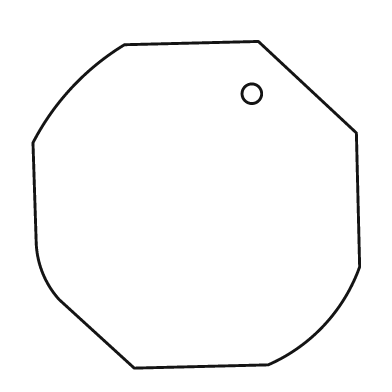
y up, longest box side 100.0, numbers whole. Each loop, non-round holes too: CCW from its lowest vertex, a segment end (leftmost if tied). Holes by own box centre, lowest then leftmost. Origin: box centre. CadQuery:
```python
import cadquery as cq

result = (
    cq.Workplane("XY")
    .moveTo(-19.0, -50.0)
    .lineTo(22.0, -49.0)
    .threePointArc((39.0, -37.0), (50.0, -19.0))
    .lineTo(49.0, 22.0)
    .lineTo(19.0, 50.0)
    .lineTo(-22.0, 49.0)
    .threePointArc((-38.0, 36.0), (-50.0, 19.0))
    .lineTo(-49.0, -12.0)
    .threePointArc((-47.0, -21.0), (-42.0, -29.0))
    .close()
    .moveTo(17.0, 34.0)
    .circle(3.0)
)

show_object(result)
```